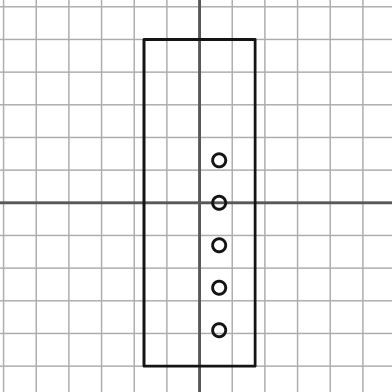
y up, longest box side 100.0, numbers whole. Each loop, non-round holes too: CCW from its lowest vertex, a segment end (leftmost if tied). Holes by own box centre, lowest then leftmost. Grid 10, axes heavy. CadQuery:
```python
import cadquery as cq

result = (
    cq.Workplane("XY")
    .moveTo(-17.0, -50.0)
    .lineTo(17.0, -50.0)
    .lineTo(17.0, 50.0)
    .lineTo(-17.0, 50.0)
    .close()
    .moveTo(6.0, -39.0)
    .circle(2.0)
    .moveTo(6.0, -26.0)
    .circle(2.0)
    .moveTo(6.0, -13.0)
    .circle(2.0)
    .moveTo(6.0, 0.0)
    .circle(2.0)
    .moveTo(6.0, 13.0)
    .circle(2.0)
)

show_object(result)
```